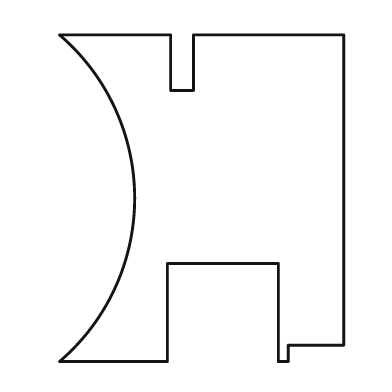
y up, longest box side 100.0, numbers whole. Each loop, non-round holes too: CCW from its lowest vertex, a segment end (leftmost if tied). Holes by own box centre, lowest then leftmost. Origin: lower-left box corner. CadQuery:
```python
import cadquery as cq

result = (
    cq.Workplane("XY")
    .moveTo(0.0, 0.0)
    .lineTo(33.0, 0.0)
    .lineTo(33.0, 30.0)
    .lineTo(67.0, 30.0)
    .lineTo(67.0, 0.0)
    .lineTo(70.0, 0.0)
    .lineTo(70.0, 5.0)
    .lineTo(87.0, 5.0)
    .lineTo(87.0, 100.0)
    .lineTo(41.0, 100.0)
    .lineTo(41.0, 83.0)
    .lineTo(34.0, 83.0)
    .lineTo(34.0, 100.0)
    .lineTo(0.0, 100.0)
    .threePointArc((23.0, 50.0), (0.0, 0.0))
    .close()
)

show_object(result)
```